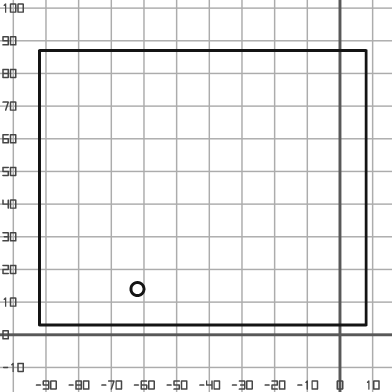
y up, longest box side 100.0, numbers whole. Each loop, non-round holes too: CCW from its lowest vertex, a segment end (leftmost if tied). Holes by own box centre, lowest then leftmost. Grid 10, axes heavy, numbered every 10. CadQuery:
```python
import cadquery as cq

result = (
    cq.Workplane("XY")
    .moveTo(-92.0, 3.0)
    .lineTo(8.0, 3.0)
    .lineTo(8.0, 87.0)
    .lineTo(-92.0, 87.0)
    .close()
    .moveTo(-62.0, 14.0)
    .circle(2.0)
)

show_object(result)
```